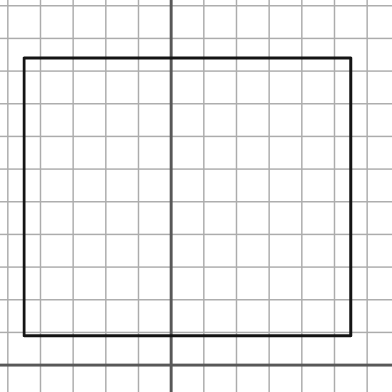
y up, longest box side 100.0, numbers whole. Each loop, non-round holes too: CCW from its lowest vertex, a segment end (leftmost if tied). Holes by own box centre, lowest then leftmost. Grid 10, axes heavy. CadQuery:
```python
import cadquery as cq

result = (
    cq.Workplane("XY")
    .moveTo(-45.0, 9.0)
    .lineTo(55.0, 9.0)
    .lineTo(55.0, 94.0)
    .lineTo(-45.0, 94.0)
    .close()
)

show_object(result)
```